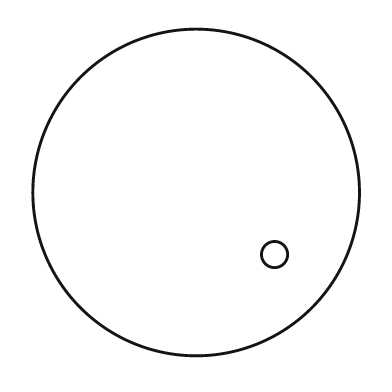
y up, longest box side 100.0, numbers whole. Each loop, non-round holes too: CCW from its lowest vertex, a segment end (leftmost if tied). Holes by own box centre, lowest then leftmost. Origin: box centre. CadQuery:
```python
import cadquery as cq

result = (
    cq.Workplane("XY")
    .moveTo(0.0, 0.0)
    .circle(50.0)
    .moveTo(24.0, -19.0)
    .circle(4.0)
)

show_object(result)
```